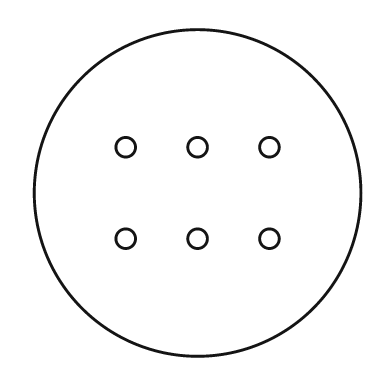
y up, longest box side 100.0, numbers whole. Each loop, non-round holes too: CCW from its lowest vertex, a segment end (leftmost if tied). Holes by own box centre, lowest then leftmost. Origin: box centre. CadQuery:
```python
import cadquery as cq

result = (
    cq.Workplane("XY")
    .moveTo(0.0, 0.0)
    .circle(50.0)
    .moveTo(-22.0, -14.0)
    .circle(3.0)
    .moveTo(0.0, -14.0)
    .circle(3.0)
    .moveTo(22.0, -14.0)
    .circle(3.0)
    .moveTo(-22.0, 14.0)
    .circle(3.0)
    .moveTo(0.0, 14.0)
    .circle(3.0)
    .moveTo(22.0, 14.0)
    .circle(3.0)
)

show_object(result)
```